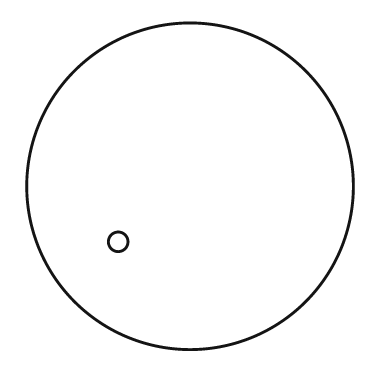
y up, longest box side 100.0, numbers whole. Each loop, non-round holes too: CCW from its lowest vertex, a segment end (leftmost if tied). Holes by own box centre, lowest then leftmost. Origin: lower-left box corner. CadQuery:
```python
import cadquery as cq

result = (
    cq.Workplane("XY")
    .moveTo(50.0, 50.0)
    .circle(50.0)
    .moveTo(28.0, 33.0)
    .circle(3.0)
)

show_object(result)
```